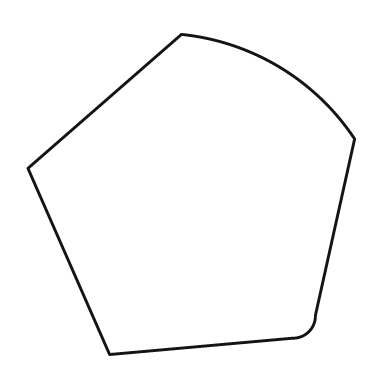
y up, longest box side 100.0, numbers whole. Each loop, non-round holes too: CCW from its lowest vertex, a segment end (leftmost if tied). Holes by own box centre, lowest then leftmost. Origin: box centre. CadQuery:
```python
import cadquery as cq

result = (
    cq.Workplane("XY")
    .moveTo(-25.0, -49.0)
    .lineTo(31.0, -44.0)
    .threePointArc((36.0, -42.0), (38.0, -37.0))
    .lineTo(50.0, 17.0)
    .threePointArc((27.0, 39.0), (-3.0, 49.0))
    .lineTo(-50.0, 8.0)
    .close()
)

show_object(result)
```